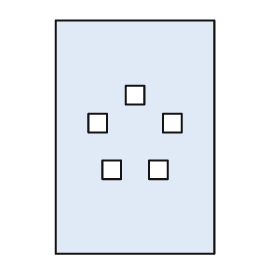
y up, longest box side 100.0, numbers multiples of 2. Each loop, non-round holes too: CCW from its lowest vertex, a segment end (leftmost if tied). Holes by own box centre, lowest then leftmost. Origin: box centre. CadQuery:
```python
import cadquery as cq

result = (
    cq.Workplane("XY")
    .moveTo(-34.0, -50.0)
    .lineTo(34.0, -50.0)
    .lineTo(34.0, 50.0)
    .lineTo(-34.0, 50.0)
    .close()
    .moveTo(-14.0, -18.0)
    .lineTo(-6.0, -18.0)
    .lineTo(-6.0, -10.0)
    .lineTo(-14.0, -10.0)
    .close()
    .moveTo(6.0, -18.0)
    .lineTo(14.0, -18.0)
    .lineTo(14.0, -10.0)
    .lineTo(6.0, -10.0)
    .close()
    .moveTo(-20.0, 2.0)
    .lineTo(-12.0, 2.0)
    .lineTo(-12.0, 10.0)
    .lineTo(-20.0, 10.0)
    .close()
    .moveTo(12.0, 2.0)
    .lineTo(20.0, 2.0)
    .lineTo(20.0, 10.0)
    .lineTo(12.0, 10.0)
    .close()
    .moveTo(-4.0, 14.0)
    .lineTo(4.0, 14.0)
    .lineTo(4.0, 22.0)
    .lineTo(-4.0, 22.0)
    .close()
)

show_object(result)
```